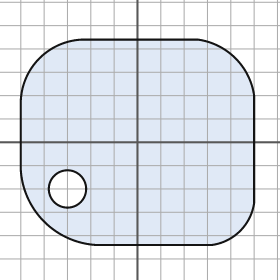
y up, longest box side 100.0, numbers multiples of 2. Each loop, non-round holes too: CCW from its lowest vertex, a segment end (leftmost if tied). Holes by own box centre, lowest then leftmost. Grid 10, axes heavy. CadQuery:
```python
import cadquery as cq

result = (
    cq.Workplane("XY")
    .moveTo(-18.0, -44.0)
    .lineTo(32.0, -44.0)
    .threePointArc((44.0, -38.0), (50.0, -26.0))
    .lineTo(50.0, 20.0)
    .threePointArc((42.0, 36.0), (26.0, 44.0))
    .lineTo(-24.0, 44.0)
    .threePointArc((-42.0, 36.0), (-50.0, 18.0))
    .lineTo(-50.0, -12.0)
    .threePointArc((-40.0, -34.0), (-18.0, -44.0))
    .close()
    .moveTo(-30.0, -20.0)
    .circle(8.0)
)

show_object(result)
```